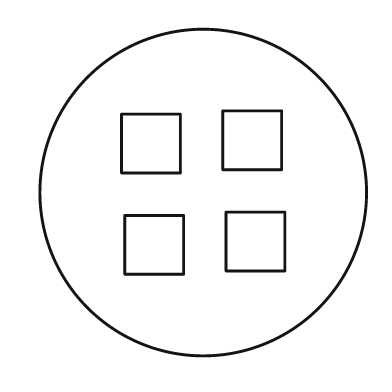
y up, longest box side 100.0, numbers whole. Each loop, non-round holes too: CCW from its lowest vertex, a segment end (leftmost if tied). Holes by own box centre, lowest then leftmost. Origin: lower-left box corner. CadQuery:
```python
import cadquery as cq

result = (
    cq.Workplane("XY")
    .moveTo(50.0, 50.0)
    .circle(50.0)
    .moveTo(26.0, 25.0)
    .lineTo(44.0, 25.0)
    .lineTo(44.0, 43.0)
    .lineTo(26.0, 43.0)
    .close()
    .moveTo(57.0, 26.0)
    .lineTo(75.0, 26.0)
    .lineTo(75.0, 44.0)
    .lineTo(57.0, 44.0)
    .close()
    .moveTo(25.0, 56.0)
    .lineTo(43.0, 56.0)
    .lineTo(43.0, 74.0)
    .lineTo(25.0, 74.0)
    .close()
    .moveTo(56.0, 57.0)
    .lineTo(74.0, 57.0)
    .lineTo(74.0, 75.0)
    .lineTo(56.0, 75.0)
    .close()
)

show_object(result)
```